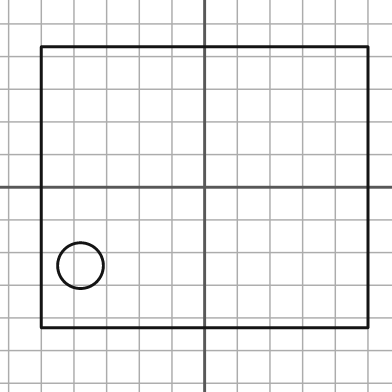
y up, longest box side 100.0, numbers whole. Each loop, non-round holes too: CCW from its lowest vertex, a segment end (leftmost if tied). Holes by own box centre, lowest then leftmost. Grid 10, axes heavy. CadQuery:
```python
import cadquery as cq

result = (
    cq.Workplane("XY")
    .moveTo(-50.0, -43.0)
    .lineTo(50.0, -43.0)
    .lineTo(50.0, 43.0)
    .lineTo(-50.0, 43.0)
    .close()
    .moveTo(-38.0, -24.0)
    .circle(7.0)
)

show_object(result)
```